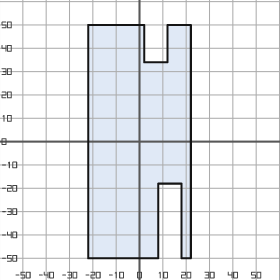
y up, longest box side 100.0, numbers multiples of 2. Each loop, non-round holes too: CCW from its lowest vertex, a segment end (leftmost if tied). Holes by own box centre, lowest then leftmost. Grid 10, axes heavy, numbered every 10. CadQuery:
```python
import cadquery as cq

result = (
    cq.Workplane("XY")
    .moveTo(-22.0, -50.0)
    .lineTo(8.0, -50.0)
    .lineTo(8.0, -18.0)
    .lineTo(18.0, -18.0)
    .lineTo(18.0, -50.0)
    .lineTo(22.0, -50.0)
    .lineTo(22.0, 50.0)
    .lineTo(12.0, 50.0)
    .lineTo(12.0, 34.0)
    .lineTo(2.0, 34.0)
    .lineTo(2.0, 50.0)
    .lineTo(-22.0, 50.0)
    .close()
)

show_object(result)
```